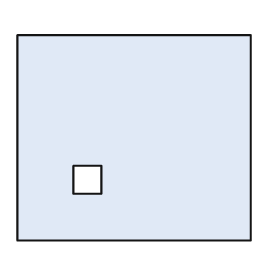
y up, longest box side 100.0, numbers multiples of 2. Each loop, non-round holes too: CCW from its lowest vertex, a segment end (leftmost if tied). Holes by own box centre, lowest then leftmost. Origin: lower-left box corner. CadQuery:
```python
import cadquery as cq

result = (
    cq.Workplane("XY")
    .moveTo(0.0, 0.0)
    .lineTo(100.0, 0.0)
    .lineTo(100.0, 88.0)
    .lineTo(0.0, 88.0)
    .close()
    .moveTo(24.0, 20.0)
    .lineTo(36.0, 20.0)
    .lineTo(36.0, 32.0)
    .lineTo(24.0, 32.0)
    .close()
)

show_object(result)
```